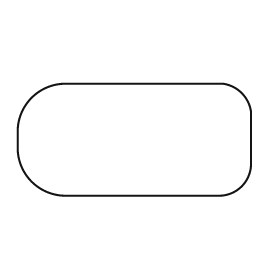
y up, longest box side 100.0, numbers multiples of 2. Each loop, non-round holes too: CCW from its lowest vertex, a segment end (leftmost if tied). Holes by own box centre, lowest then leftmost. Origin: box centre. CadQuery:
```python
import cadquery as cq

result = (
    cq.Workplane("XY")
    .moveTo(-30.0, -24.0)
    .lineTo(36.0, -24.0)
    .threePointArc((46.0, -20.0), (50.0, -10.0))
    .lineTo(50.0, 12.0)
    .threePointArc((46.0, 20.0), (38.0, 24.0))
    .lineTo(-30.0, 24.0)
    .threePointArc((-44.0, 18.0), (-50.0, 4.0))
    .lineTo(-50.0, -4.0)
    .threePointArc((-44.0, -18.0), (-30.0, -24.0))
    .close()
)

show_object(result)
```